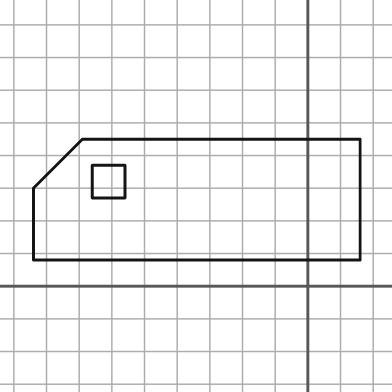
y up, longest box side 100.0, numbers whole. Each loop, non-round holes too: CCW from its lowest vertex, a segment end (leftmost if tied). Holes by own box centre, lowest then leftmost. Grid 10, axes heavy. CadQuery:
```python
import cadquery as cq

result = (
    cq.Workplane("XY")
    .moveTo(-84.0, 8.0)
    .lineTo(16.0, 8.0)
    .lineTo(16.0, 45.0)
    .lineTo(-69.0, 45.0)
    .lineTo(-84.0, 30.0)
    .close()
    .moveTo(-66.0, 27.0)
    .lineTo(-56.0, 27.0)
    .lineTo(-56.0, 37.0)
    .lineTo(-66.0, 37.0)
    .close()
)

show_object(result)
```